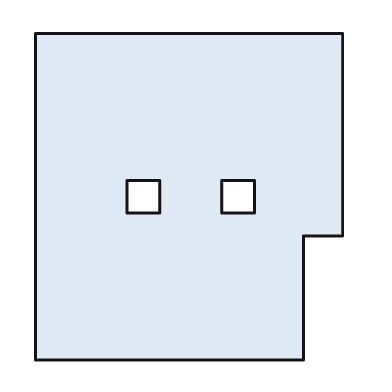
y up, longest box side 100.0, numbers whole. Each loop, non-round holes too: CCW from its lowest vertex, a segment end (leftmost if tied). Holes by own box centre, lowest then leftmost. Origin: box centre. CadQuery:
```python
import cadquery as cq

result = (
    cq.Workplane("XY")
    .moveTo(-47.0, -50.0)
    .lineTo(35.0, -50.0)
    .lineTo(35.0, -12.0)
    .lineTo(47.0, -12.0)
    .lineTo(47.0, 50.0)
    .lineTo(-47.0, 50.0)
    .close()
    .moveTo(-19.0, -5.0)
    .lineTo(-9.0, -5.0)
    .lineTo(-9.0, 5.0)
    .lineTo(-19.0, 5.0)
    .close()
    .moveTo(10.0, -5.0)
    .lineTo(20.0, -5.0)
    .lineTo(20.0, 5.0)
    .lineTo(10.0, 5.0)
    .close()
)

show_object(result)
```